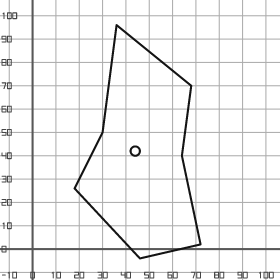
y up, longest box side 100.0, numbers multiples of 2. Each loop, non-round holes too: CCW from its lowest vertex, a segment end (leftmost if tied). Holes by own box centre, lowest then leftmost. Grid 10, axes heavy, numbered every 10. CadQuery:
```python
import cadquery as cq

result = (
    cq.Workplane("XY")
    .moveTo(46.0, -4.0)
    .lineTo(72.0, 2.0)
    .lineTo(64.0, 40.0)
    .lineTo(68.0, 70.0)
    .lineTo(36.0, 96.0)
    .lineTo(30.0, 50.0)
    .lineTo(18.0, 26.0)
    .close()
    .moveTo(44.0, 42.0)
    .circle(2.0)
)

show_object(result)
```